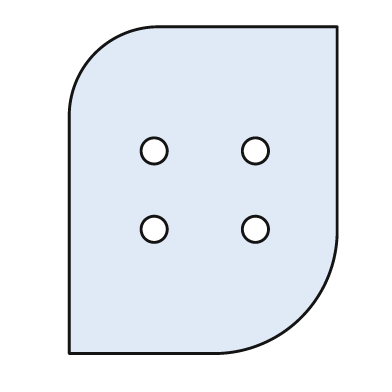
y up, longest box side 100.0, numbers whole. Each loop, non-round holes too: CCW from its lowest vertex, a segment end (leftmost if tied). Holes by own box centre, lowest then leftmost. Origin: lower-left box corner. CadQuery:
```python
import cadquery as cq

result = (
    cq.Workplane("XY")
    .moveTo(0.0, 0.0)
    .lineTo(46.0, 0.0)
    .threePointArc((71.0, 11.0), (82.0, 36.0))
    .lineTo(82.0, 100.0)
    .lineTo(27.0, 100.0)
    .threePointArc((8.0, 92.0), (0.0, 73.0))
    .close()
    .moveTo(26.0, 38.0)
    .circle(4.0)
    .moveTo(57.0, 38.0)
    .circle(4.0)
    .moveTo(26.0, 62.0)
    .circle(4.0)
    .moveTo(57.0, 62.0)
    .circle(4.0)
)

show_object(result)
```